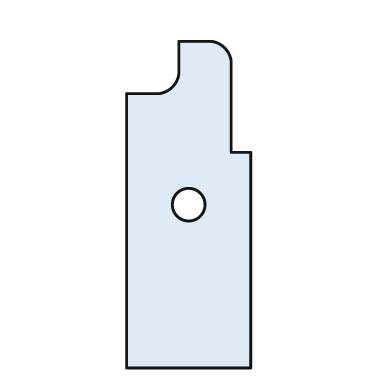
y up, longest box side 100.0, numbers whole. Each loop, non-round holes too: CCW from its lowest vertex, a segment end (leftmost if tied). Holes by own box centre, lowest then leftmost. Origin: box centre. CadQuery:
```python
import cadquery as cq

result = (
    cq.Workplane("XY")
    .moveTo(-19.0, -50.0)
    .lineTo(19.0, -50.0)
    .lineTo(19.0, 16.0)
    .lineTo(13.0, 16.0)
    .lineTo(13.0, 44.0)
    .threePointArc((11.0, 48.0), (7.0, 50.0))
    .lineTo(-3.0, 50.0)
    .lineTo(-3.0, 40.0)
    .threePointArc((-5.0, 36.0), (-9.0, 34.0))
    .lineTo(-19.0, 34.0)
    .close()
    .moveTo(0.0, 0.0)
    .circle(5.0)
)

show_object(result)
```